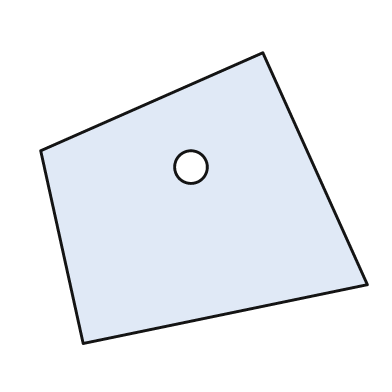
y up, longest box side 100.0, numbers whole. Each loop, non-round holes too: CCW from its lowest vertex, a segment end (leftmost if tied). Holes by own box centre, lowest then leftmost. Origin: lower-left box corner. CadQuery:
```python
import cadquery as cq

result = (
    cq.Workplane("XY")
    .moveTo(13.0, 0.0)
    .lineTo(100.0, 18.0)
    .lineTo(68.0, 89.0)
    .lineTo(0.0, 59.0)
    .close()
    .moveTo(46.0, 54.0)
    .circle(5.0)
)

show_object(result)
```